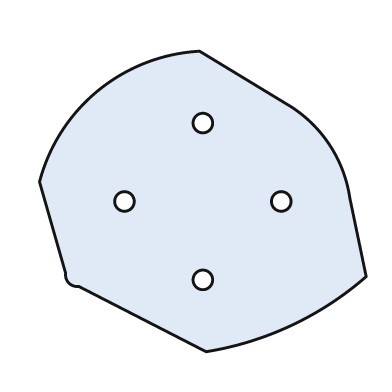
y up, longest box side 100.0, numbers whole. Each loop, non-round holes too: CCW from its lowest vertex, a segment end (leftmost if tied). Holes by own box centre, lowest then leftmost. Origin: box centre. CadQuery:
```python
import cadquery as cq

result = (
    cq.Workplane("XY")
    .moveTo(1.0, -46.0)
    .threePointArc((27.0, -38.0), (50.0, -23.0))
    .lineTo(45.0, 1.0)
    .threePointArc((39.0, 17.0), (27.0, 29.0))
    .lineTo(-1.0, 46.0)
    .threePointArc((-32.0, 34.0), (-50.0, 6.0))
    .lineTo(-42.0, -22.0)
    .threePointArc((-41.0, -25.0), (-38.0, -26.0))
    .close()
    .moveTo(0.0, -24.0)
    .circle(3.0)
    .moveTo(-24.0, 0.0)
    .circle(3.0)
    .moveTo(24.0, 0.0)
    .circle(3.0)
    .moveTo(0.0, 24.0)
    .circle(3.0)
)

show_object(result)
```